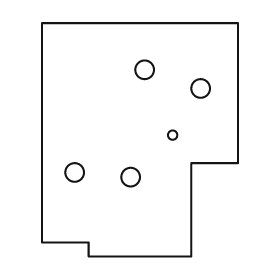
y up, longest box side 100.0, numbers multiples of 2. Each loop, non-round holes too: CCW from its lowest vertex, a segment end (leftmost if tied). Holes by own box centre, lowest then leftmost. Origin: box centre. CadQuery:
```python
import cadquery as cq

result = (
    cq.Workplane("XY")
    .moveTo(-22.0, -50.0)
    .lineTo(22.0, -50.0)
    .lineTo(22.0, -10.0)
    .lineTo(42.0, -10.0)
    .lineTo(42.0, 50.0)
    .lineTo(-42.0, 50.0)
    .lineTo(-42.0, -44.0)
    .lineTo(-22.0, -44.0)
    .close()
    .moveTo(-4.0, -16.0)
    .circle(4.0)
    .moveTo(-28.0, -14.0)
    .circle(4.0)
    .moveTo(14.0, 2.0)
    .circle(2.0)
    .moveTo(26.0, 22.0)
    .circle(4.0)
    .moveTo(2.0, 30.0)
    .circle(4.0)
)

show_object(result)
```